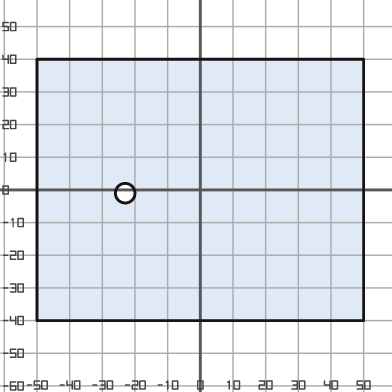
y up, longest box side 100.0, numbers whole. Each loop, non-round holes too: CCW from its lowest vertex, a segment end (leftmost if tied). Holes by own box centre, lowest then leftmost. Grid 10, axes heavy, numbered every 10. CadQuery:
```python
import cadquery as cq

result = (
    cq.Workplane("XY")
    .moveTo(-50.0, -40.0)
    .lineTo(50.0, -40.0)
    .lineTo(50.0, 40.0)
    .lineTo(-50.0, 40.0)
    .close()
    .moveTo(-23.0, -1.0)
    .circle(3.0)
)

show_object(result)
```